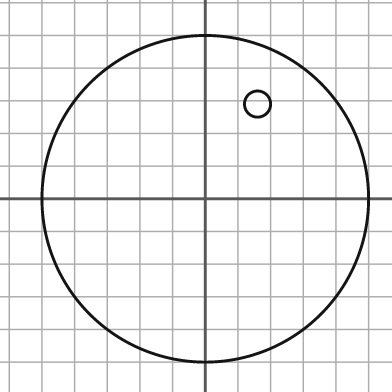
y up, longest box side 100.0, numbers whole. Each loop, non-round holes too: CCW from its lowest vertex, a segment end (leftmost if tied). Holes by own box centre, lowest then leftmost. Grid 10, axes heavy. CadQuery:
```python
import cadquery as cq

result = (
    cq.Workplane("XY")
    .moveTo(0.0, 0.0)
    .circle(50.0)
    .moveTo(16.0, 29.0)
    .circle(4.0)
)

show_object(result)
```